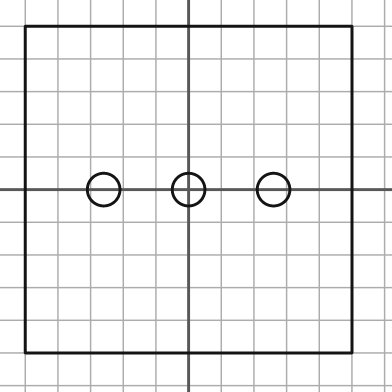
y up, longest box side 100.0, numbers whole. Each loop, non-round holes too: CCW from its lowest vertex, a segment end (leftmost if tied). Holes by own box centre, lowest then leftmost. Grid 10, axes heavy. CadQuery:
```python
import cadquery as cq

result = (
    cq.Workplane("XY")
    .moveTo(-50.0, -50.0)
    .lineTo(50.0, -50.0)
    .lineTo(50.0, 50.0)
    .lineTo(-50.0, 50.0)
    .close()
    .moveTo(-26.0, 0.0)
    .circle(5.0)
    .moveTo(0.0, 0.0)
    .circle(5.0)
    .moveTo(26.0, 0.0)
    .circle(5.0)
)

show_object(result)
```